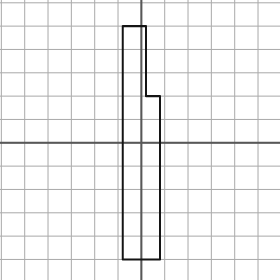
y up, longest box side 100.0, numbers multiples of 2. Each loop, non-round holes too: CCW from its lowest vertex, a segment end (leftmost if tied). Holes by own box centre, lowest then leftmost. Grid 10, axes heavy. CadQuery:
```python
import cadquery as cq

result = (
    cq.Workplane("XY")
    .moveTo(-8.0, -50.0)
    .lineTo(8.0, -50.0)
    .lineTo(8.0, 20.0)
    .lineTo(2.0, 20.0)
    .lineTo(2.0, 50.0)
    .lineTo(-8.0, 50.0)
    .close()
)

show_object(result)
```